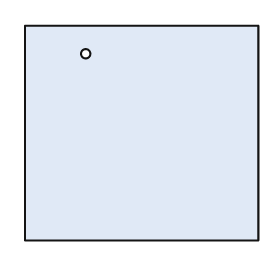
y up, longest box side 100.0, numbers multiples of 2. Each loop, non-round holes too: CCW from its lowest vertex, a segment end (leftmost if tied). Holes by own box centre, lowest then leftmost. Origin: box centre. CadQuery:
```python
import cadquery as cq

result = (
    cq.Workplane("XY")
    .moveTo(-50.0, -46.0)
    .lineTo(50.0, -46.0)
    .lineTo(50.0, 46.0)
    .lineTo(-50.0, 46.0)
    .close()
    .moveTo(-24.0, 34.0)
    .circle(2.0)
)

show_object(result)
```